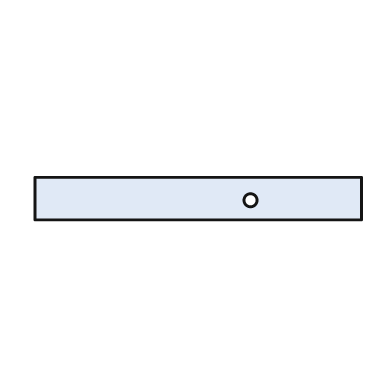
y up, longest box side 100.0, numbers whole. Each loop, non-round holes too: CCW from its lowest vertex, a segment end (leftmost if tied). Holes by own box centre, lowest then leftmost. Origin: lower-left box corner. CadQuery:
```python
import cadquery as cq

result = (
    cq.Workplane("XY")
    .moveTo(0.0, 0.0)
    .lineTo(100.0, 0.0)
    .lineTo(100.0, 13.0)
    .lineTo(0.0, 13.0)
    .close()
    .moveTo(66.0, 6.0)
    .circle(2.0)
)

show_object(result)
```